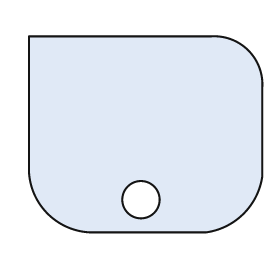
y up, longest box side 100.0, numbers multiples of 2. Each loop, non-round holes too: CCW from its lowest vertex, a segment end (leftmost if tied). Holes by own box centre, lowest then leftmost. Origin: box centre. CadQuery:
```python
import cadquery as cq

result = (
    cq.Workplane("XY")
    .moveTo(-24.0, -42.0)
    .lineTo(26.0, -42.0)
    .threePointArc((42.0, -34.0), (50.0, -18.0))
    .lineTo(50.0, 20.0)
    .threePointArc((44.0, 36.0), (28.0, 42.0))
    .lineTo(-50.0, 42.0)
    .lineTo(-50.0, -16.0)
    .threePointArc((-42.0, -34.0), (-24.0, -42.0))
    .close()
    .moveTo(-2.0, -28.0)
    .circle(8.0)
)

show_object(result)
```